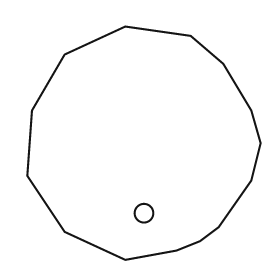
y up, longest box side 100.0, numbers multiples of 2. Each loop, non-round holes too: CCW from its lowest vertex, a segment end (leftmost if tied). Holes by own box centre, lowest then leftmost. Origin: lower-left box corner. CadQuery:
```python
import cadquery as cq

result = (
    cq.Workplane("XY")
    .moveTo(42.0, 0.0)
    .lineTo(64.0, 4.0)
    .lineTo(74.0, 8.0)
    .lineTo(82.0, 14.0)
    .lineTo(96.0, 34.0)
    .lineTo(100.0, 50.0)
    .lineTo(96.0, 64.0)
    .lineTo(84.0, 84.0)
    .lineTo(70.0, 96.0)
    .lineTo(42.0, 100.0)
    .lineTo(16.0, 88.0)
    .lineTo(2.0, 64.0)
    .lineTo(0.0, 36.0)
    .lineTo(16.0, 12.0)
    .close()
    .moveTo(50.0, 20.0)
    .circle(4.0)
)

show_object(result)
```